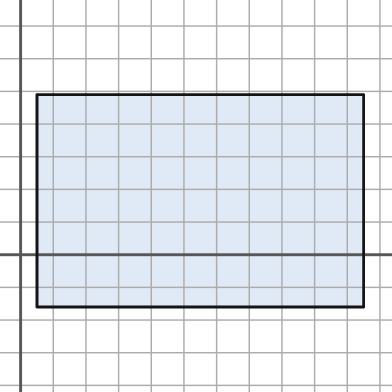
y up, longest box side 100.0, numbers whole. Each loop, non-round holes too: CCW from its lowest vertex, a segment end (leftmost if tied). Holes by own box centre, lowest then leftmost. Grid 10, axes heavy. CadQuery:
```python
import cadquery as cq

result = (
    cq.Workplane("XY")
    .moveTo(5.0, -16.0)
    .lineTo(105.0, -16.0)
    .lineTo(105.0, 49.0)
    .lineTo(5.0, 49.0)
    .close()
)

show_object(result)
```